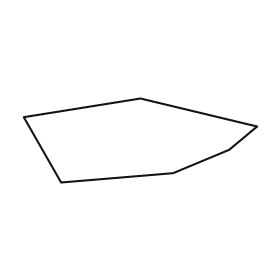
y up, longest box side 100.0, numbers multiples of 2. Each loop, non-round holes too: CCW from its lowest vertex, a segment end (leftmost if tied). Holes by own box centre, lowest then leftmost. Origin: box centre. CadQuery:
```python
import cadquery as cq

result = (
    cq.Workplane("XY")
    .moveTo(-34.0, -18.0)
    .lineTo(14.0, -14.0)
    .lineTo(38.0, -4.0)
    .lineTo(50.0, 6.0)
    .lineTo(0.0, 18.0)
    .lineTo(-50.0, 10.0)
    .close()
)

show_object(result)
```